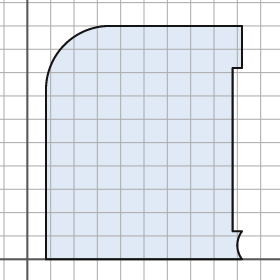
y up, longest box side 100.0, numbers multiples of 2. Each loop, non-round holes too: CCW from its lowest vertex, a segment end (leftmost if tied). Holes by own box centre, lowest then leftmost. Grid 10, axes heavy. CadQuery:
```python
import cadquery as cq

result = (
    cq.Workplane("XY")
    .moveTo(8.0, 0.0)
    .lineTo(92.0, 0.0)
    .threePointArc((90.0, 6.0), (92.0, 12.0))
    .lineTo(88.0, 12.0)
    .lineTo(88.0, 82.0)
    .lineTo(92.0, 82.0)
    .lineTo(92.0, 100.0)
    .lineTo(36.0, 100.0)
    .threePointArc((16.0, 92.0), (8.0, 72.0))
    .close()
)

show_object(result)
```